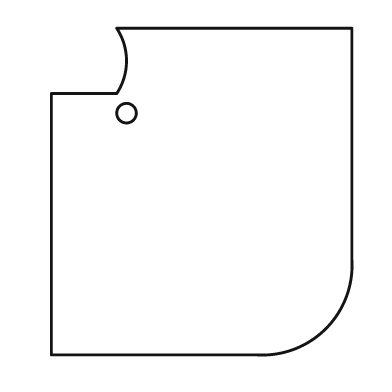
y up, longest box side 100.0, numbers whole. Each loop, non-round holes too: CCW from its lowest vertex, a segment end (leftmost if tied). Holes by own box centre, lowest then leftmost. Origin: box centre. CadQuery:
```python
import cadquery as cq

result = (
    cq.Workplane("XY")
    .moveTo(-46.0, -50.0)
    .lineTo(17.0, -50.0)
    .threePointArc((38.0, -42.0), (46.0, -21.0))
    .lineTo(46.0, 50.0)
    .lineTo(-26.0, 50.0)
    .threePointArc((-23.0, 40.0), (-26.0, 30.0))
    .lineTo(-46.0, 30.0)
    .close()
    .moveTo(-23.0, 24.0)
    .circle(3.0)
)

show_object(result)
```